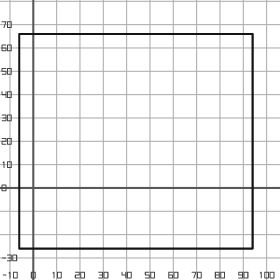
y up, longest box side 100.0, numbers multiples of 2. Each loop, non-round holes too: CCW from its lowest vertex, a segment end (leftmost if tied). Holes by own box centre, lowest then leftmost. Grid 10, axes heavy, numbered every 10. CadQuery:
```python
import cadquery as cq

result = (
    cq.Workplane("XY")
    .moveTo(-6.0, -26.0)
    .lineTo(94.0, -26.0)
    .lineTo(94.0, 66.0)
    .lineTo(-6.0, 66.0)
    .close()
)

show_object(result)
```